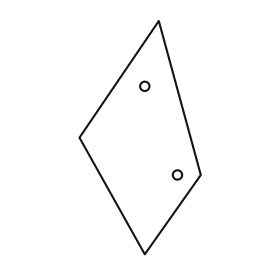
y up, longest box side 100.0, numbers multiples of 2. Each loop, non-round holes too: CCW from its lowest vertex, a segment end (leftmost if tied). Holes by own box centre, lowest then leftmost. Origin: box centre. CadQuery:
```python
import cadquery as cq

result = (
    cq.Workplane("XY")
    .moveTo(2.0, -50.0)
    .lineTo(26.0, -16.0)
    .lineTo(8.0, 50.0)
    .lineTo(-26.0, 0.0)
    .close()
    .moveTo(16.0, -16.0)
    .circle(2.0)
    .moveTo(2.0, 22.0)
    .circle(2.0)
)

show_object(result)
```